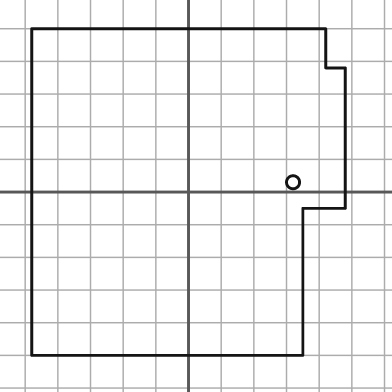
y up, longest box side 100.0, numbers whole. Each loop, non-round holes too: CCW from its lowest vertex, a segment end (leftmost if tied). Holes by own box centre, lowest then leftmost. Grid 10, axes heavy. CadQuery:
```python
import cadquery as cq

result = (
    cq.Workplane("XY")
    .moveTo(-48.0, -50.0)
    .lineTo(35.0, -50.0)
    .lineTo(35.0, -5.0)
    .lineTo(48.0, -5.0)
    .lineTo(48.0, 38.0)
    .lineTo(42.0, 38.0)
    .lineTo(42.0, 50.0)
    .lineTo(-48.0, 50.0)
    .close()
    .moveTo(32.0, 3.0)
    .circle(2.0)
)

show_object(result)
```